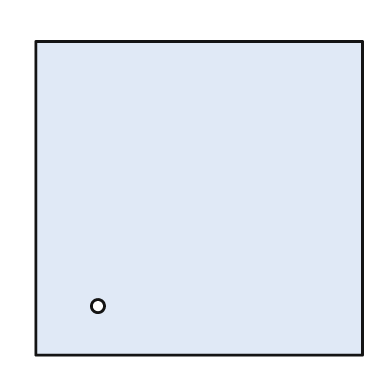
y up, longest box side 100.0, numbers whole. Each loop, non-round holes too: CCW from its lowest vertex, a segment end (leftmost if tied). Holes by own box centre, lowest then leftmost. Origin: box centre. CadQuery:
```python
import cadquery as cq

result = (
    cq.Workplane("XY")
    .moveTo(-50.0, -48.0)
    .lineTo(50.0, -48.0)
    .lineTo(50.0, 48.0)
    .lineTo(-50.0, 48.0)
    .close()
    .moveTo(-31.0, -33.0)
    .circle(2.0)
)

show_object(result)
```